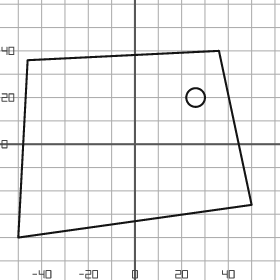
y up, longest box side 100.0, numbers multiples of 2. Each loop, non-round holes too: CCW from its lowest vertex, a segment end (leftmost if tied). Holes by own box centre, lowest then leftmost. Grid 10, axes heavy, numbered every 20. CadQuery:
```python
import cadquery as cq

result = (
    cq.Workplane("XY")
    .moveTo(-50.0, -40.0)
    .lineTo(50.0, -26.0)
    .lineTo(36.0, 40.0)
    .lineTo(-46.0, 36.0)
    .close()
    .moveTo(26.0, 20.0)
    .circle(4.0)
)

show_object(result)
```